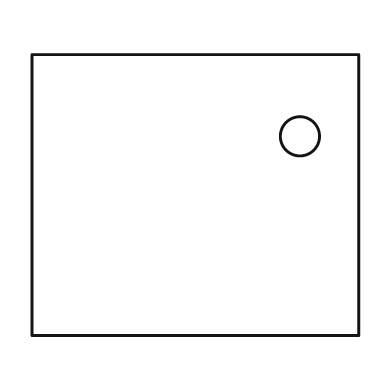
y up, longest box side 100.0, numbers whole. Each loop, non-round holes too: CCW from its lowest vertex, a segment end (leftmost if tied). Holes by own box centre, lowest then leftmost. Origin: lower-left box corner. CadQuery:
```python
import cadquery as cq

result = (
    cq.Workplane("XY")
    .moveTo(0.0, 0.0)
    .lineTo(100.0, 0.0)
    .lineTo(100.0, 86.0)
    .lineTo(0.0, 86.0)
    .close()
    .moveTo(82.0, 61.0)
    .circle(6.0)
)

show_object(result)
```